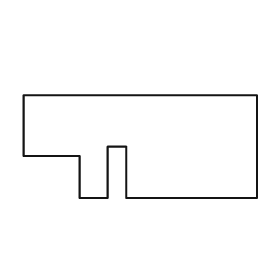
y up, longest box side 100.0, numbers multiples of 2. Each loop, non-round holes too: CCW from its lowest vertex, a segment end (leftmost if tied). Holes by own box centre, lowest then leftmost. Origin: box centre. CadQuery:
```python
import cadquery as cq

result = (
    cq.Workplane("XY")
    .moveTo(-26.0, -22.0)
    .lineTo(-14.0, -22.0)
    .lineTo(-14.0, 0.0)
    .lineTo(-6.0, 0.0)
    .lineTo(-6.0, -22.0)
    .lineTo(50.0, -22.0)
    .lineTo(50.0, 22.0)
    .lineTo(-50.0, 22.0)
    .lineTo(-50.0, -4.0)
    .lineTo(-26.0, -4.0)
    .close()
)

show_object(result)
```